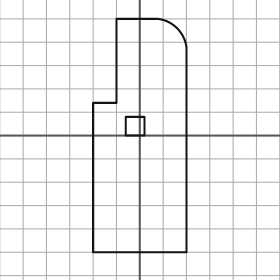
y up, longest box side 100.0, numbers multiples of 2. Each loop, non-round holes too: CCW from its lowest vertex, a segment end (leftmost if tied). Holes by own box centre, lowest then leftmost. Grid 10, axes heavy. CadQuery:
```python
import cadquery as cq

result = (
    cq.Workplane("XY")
    .moveTo(-20.0, -50.0)
    .lineTo(20.0, -50.0)
    .lineTo(20.0, 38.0)
    .threePointArc((16.0, 46.0), (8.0, 50.0))
    .lineTo(-10.0, 50.0)
    .lineTo(-10.0, 14.0)
    .lineTo(-20.0, 14.0)
    .close()
    .moveTo(-6.0, 0.0)
    .lineTo(2.0, 0.0)
    .lineTo(2.0, 8.0)
    .lineTo(-6.0, 8.0)
    .close()
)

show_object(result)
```